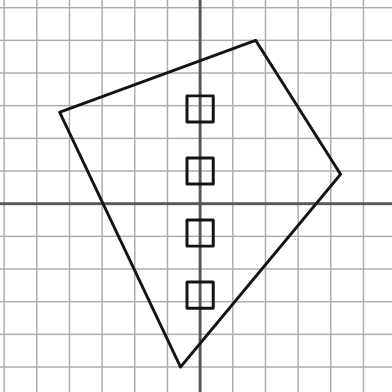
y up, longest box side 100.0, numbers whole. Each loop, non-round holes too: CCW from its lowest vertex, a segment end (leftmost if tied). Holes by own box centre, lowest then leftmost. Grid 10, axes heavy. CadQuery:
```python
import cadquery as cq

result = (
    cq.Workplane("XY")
    .moveTo(-6.0, -50.0)
    .lineTo(43.0, 9.0)
    .lineTo(17.0, 50.0)
    .lineTo(-43.0, 28.0)
    .close()
    .moveTo(-4.0, -32.0)
    .lineTo(4.0, -32.0)
    .lineTo(4.0, -24.0)
    .lineTo(-4.0, -24.0)
    .close()
    .moveTo(-4.0, -13.0)
    .lineTo(4.0, -13.0)
    .lineTo(4.0, -5.0)
    .lineTo(-4.0, -5.0)
    .close()
    .moveTo(-4.0, 6.0)
    .lineTo(4.0, 6.0)
    .lineTo(4.0, 14.0)
    .lineTo(-4.0, 14.0)
    .close()
    .moveTo(-4.0, 25.0)
    .lineTo(4.0, 25.0)
    .lineTo(4.0, 33.0)
    .lineTo(-4.0, 33.0)
    .close()
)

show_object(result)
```